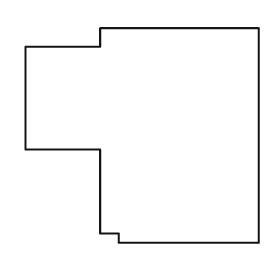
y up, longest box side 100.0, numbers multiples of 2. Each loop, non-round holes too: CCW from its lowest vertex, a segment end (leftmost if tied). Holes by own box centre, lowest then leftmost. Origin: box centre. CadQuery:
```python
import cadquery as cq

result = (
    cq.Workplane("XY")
    .moveTo(-10.0, -46.0)
    .lineTo(50.0, -46.0)
    .lineTo(50.0, 46.0)
    .lineTo(-18.0, 46.0)
    .lineTo(-18.0, 38.0)
    .lineTo(-50.0, 38.0)
    .lineTo(-50.0, -6.0)
    .lineTo(-18.0, -6.0)
    .lineTo(-18.0, -42.0)
    .lineTo(-10.0, -42.0)
    .close()
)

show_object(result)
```